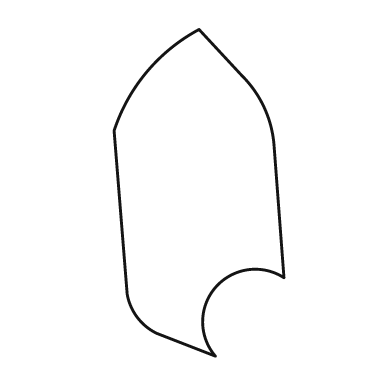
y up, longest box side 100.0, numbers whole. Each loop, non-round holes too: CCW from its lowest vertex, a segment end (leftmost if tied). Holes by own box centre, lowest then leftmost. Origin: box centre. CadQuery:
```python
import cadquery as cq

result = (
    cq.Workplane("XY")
    .moveTo(5.0, -50.0)
    .threePointArc((5.0, -29.0), (26.0, -26.0))
    .lineTo(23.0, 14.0)
    .threePointArc((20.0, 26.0), (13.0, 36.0))
    .lineTo(0.0, 50.0)
    .threePointArc((-16.0, 37.0), (-26.0, 19.0))
    .lineTo(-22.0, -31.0)
    .threePointArc((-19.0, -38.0), (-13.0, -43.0))
    .close()
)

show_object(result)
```